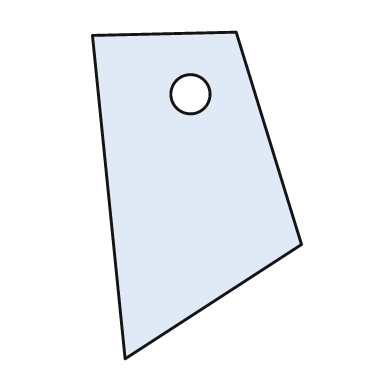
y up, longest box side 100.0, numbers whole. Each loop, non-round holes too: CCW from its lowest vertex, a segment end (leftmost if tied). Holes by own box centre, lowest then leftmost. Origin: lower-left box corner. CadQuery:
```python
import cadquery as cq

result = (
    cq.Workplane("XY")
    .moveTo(10.0, 0.0)
    .lineTo(64.0, 35.0)
    .lineTo(44.0, 100.0)
    .lineTo(0.0, 99.0)
    .close()
    .moveTo(30.0, 81.0)
    .circle(6.0)
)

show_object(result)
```